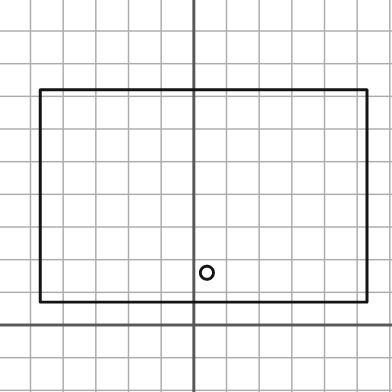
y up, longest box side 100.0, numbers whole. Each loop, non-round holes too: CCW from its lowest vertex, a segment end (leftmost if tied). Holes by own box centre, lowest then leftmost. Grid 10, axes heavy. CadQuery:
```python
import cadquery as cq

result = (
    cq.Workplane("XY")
    .moveTo(-47.0, 7.0)
    .lineTo(53.0, 7.0)
    .lineTo(53.0, 72.0)
    .lineTo(-47.0, 72.0)
    .close()
    .moveTo(4.0, 16.0)
    .circle(2.0)
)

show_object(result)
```